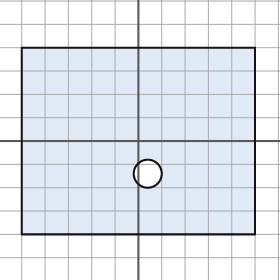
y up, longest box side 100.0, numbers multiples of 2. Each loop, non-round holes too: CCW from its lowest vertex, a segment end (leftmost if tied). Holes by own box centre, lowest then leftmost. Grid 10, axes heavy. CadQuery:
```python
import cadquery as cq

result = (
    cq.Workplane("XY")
    .moveTo(-50.0, -40.0)
    .lineTo(50.0, -40.0)
    .lineTo(50.0, 40.0)
    .lineTo(-50.0, 40.0)
    .close()
    .moveTo(4.0, -14.0)
    .circle(6.0)
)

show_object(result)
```